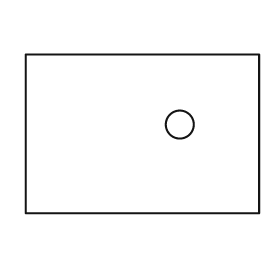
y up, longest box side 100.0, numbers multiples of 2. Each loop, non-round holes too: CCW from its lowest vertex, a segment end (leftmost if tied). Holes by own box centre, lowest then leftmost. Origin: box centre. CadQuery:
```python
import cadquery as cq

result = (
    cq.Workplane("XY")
    .moveTo(-50.0, -34.0)
    .lineTo(50.0, -34.0)
    .lineTo(50.0, 34.0)
    .lineTo(-50.0, 34.0)
    .close()
    .moveTo(16.0, 4.0)
    .circle(6.0)
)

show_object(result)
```